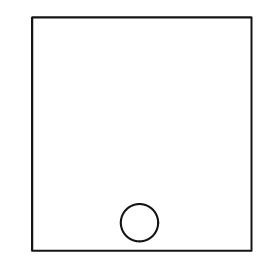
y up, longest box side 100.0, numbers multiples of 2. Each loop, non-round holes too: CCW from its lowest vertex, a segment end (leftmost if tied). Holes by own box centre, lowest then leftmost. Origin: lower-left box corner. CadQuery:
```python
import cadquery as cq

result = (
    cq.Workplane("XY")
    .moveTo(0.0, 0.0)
    .lineTo(94.0, 0.0)
    .lineTo(94.0, 100.0)
    .lineTo(0.0, 100.0)
    .close()
    .moveTo(46.0, 12.0)
    .circle(8.0)
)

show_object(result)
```